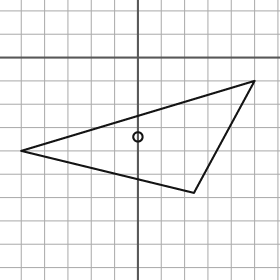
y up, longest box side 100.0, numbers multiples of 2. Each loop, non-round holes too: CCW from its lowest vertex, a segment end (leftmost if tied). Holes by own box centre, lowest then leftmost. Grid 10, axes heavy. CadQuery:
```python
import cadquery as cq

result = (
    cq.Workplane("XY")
    .moveTo(24.0, -58.0)
    .lineTo(50.0, -10.0)
    .lineTo(-50.0, -40.0)
    .close()
    .moveTo(0.0, -34.0)
    .circle(2.0)
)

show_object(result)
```